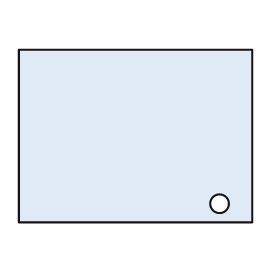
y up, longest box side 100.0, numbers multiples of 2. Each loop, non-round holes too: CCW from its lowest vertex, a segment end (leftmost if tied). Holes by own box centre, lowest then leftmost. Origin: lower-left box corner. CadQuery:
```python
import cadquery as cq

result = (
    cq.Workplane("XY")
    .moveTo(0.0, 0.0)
    .lineTo(100.0, 0.0)
    .lineTo(100.0, 74.0)
    .lineTo(0.0, 74.0)
    .close()
    .moveTo(86.0, 8.0)
    .circle(4.0)
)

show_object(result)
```